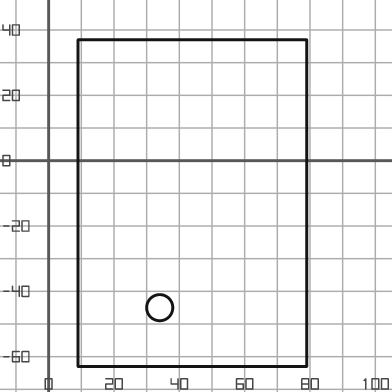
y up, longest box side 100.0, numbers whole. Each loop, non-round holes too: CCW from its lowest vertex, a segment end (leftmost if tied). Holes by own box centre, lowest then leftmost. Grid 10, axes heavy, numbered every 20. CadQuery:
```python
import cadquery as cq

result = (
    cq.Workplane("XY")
    .moveTo(9.0, -63.0)
    .lineTo(79.0, -63.0)
    .lineTo(79.0, 37.0)
    .lineTo(9.0, 37.0)
    .close()
    .moveTo(34.0, -45.0)
    .circle(4.0)
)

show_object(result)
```